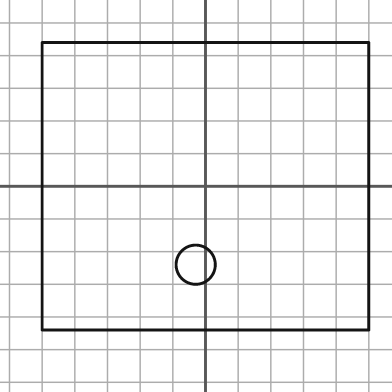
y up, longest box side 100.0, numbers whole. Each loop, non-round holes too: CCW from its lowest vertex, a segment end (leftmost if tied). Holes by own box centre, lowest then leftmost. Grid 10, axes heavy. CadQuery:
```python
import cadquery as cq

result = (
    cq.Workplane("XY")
    .moveTo(-50.0, -44.0)
    .lineTo(50.0, -44.0)
    .lineTo(50.0, 44.0)
    .lineTo(-50.0, 44.0)
    .close()
    .moveTo(-3.0, -24.0)
    .circle(6.0)
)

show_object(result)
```